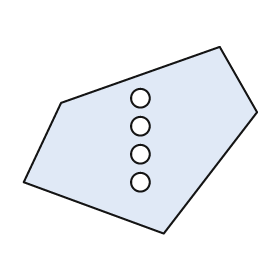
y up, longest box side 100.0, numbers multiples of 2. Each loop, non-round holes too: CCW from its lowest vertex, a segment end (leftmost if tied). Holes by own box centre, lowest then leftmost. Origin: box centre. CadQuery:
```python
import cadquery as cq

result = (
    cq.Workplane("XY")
    .moveTo(10.0, -40.0)
    .lineTo(50.0, 12.0)
    .lineTo(34.0, 40.0)
    .lineTo(-34.0, 16.0)
    .lineTo(-50.0, -18.0)
    .close()
    .moveTo(0.0, -18.0)
    .circle(4.0)
    .moveTo(0.0, -6.0)
    .circle(4.0)
    .moveTo(0.0, 6.0)
    .circle(4.0)
    .moveTo(0.0, 18.0)
    .circle(4.0)
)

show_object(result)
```